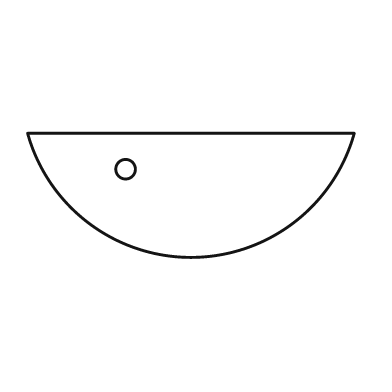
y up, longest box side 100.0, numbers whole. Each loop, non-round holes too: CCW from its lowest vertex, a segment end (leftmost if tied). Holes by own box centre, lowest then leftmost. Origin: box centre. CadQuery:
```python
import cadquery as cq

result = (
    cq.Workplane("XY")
    .moveTo(-50.0, 19.0)
    .threePointArc((0.0, -19.0), (50.0, 19.0))
    .close()
    .moveTo(-20.0, 8.0)
    .circle(3.0)
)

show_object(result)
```